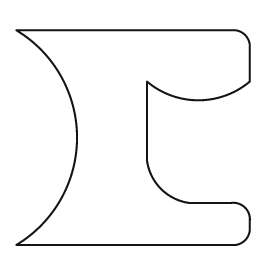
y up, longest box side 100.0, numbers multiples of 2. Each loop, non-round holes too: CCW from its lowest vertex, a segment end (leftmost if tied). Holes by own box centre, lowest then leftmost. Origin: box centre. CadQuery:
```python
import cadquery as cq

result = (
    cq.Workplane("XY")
    .moveTo(-50.0, -46.0)
    .lineTo(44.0, -46.0)
    .threePointArc((48.0, -44.0), (50.0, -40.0))
    .lineTo(50.0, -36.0)
    .threePointArc((48.0, -30.0), (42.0, -28.0))
    .lineTo(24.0, -28.0)
    .threePointArc((12.0, -22.0), (6.0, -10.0))
    .lineTo(6.0, 24.0)
    .threePointArc((28.0, 16.0), (50.0, 24.0))
    .lineTo(50.0, 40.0)
    .threePointArc((48.0, 44.0), (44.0, 46.0))
    .lineTo(-50.0, 46.0)
    .threePointArc((-24.0, 0.0), (-50.0, -46.0))
    .close()
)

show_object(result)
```